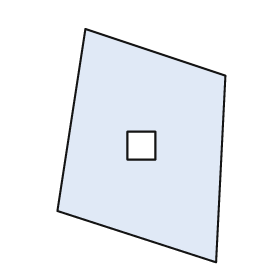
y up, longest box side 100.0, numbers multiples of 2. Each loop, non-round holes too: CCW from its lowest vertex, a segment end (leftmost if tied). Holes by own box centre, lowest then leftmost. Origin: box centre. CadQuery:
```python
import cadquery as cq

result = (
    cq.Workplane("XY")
    .moveTo(32.0, -50.0)
    .lineTo(36.0, 30.0)
    .lineTo(-24.0, 50.0)
    .lineTo(-36.0, -28.0)
    .close()
    .moveTo(-6.0, -6.0)
    .lineTo(6.0, -6.0)
    .lineTo(6.0, 6.0)
    .lineTo(-6.0, 6.0)
    .close()
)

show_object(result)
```